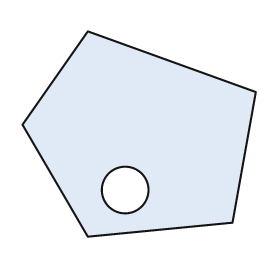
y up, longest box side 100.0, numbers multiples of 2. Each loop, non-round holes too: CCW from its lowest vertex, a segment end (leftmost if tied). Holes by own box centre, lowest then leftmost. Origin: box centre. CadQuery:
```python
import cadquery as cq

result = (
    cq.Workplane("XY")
    .moveTo(-22.0, -44.0)
    .lineTo(40.0, -38.0)
    .lineTo(50.0, 18.0)
    .lineTo(-22.0, 44.0)
    .lineTo(-50.0, 4.0)
    .close()
    .moveTo(-6.0, -24.0)
    .circle(10.0)
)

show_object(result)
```